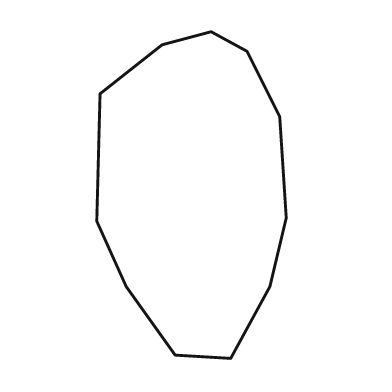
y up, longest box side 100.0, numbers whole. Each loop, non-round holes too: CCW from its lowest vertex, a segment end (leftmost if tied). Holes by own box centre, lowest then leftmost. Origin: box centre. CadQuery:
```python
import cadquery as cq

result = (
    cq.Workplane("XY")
    .moveTo(12.0, -50.0)
    .lineTo(24.0, -28.0)
    .lineTo(29.0, -7.0)
    .lineTo(27.0, 24.0)
    .lineTo(17.0, 44.0)
    .lineTo(6.0, 50.0)
    .lineTo(-9.0, 46.0)
    .lineTo(-28.0, 31.0)
    .lineTo(-29.0, -8.0)
    .lineTo(-20.0, -28.0)
    .lineTo(-5.0, -49.0)
    .close()
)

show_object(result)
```